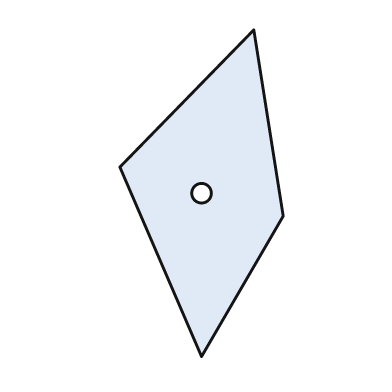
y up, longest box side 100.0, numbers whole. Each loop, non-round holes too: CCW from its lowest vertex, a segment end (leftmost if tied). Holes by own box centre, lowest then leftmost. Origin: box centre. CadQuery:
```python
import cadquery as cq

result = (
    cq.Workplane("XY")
    .moveTo(0.0, -50.0)
    .lineTo(25.0, -7.0)
    .lineTo(16.0, 50.0)
    .lineTo(-25.0, 8.0)
    .close()
    .moveTo(0.0, 0.0)
    .circle(3.0)
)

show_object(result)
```